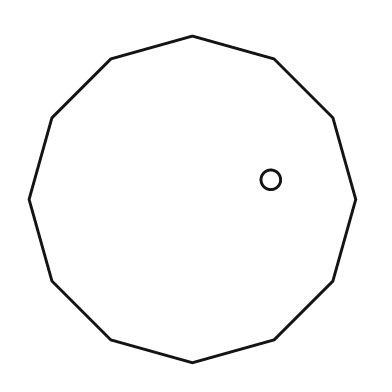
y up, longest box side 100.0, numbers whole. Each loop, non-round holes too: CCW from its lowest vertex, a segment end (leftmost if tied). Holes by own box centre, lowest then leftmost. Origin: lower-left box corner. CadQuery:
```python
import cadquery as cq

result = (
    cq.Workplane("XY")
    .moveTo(50.0, 0.0)
    .lineTo(75.0, 7.0)
    .lineTo(93.0, 25.0)
    .lineTo(100.0, 50.0)
    .lineTo(93.0, 75.0)
    .lineTo(75.0, 93.0)
    .lineTo(50.0, 100.0)
    .lineTo(25.0, 93.0)
    .lineTo(7.0, 75.0)
    .lineTo(0.0, 50.0)
    .lineTo(7.0, 25.0)
    .lineTo(25.0, 7.0)
    .close()
    .moveTo(74.0, 56.0)
    .circle(3.0)
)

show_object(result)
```